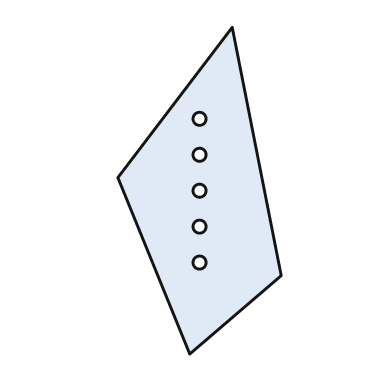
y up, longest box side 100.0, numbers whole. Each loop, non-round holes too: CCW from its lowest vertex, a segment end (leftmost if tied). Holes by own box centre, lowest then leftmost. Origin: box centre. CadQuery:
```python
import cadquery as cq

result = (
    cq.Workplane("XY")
    .moveTo(-3.0, -50.0)
    .lineTo(25.0, -26.0)
    .lineTo(10.0, 50.0)
    .lineTo(-25.0, 4.0)
    .close()
    .moveTo(0.0, -22.0)
    .circle(2.0)
    .moveTo(0.0, -11.0)
    .circle(2.0)
    .moveTo(0.0, 0.0)
    .circle(2.0)
    .moveTo(0.0, 11.0)
    .circle(2.0)
    .moveTo(0.0, 22.0)
    .circle(2.0)
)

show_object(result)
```